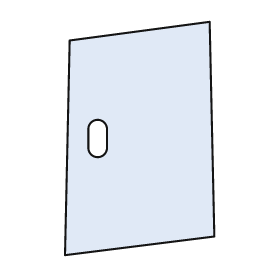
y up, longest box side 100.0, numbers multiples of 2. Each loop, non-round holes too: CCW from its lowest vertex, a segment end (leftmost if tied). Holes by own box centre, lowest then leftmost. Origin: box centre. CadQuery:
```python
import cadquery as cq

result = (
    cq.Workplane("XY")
    .moveTo(-32.0, -50.0)
    .lineTo(32.0, -42.0)
    .lineTo(30.0, 50.0)
    .lineTo(-30.0, 42.0)
    .close()
    .moveTo(-22.0, -4.0)
    .threePointArc((-18.0, -8.0), (-14.0, -4.0))
    .lineTo(-14.0, 4.0)
    .threePointArc((-18.0, 8.0), (-22.0, 4.0))
    .close()
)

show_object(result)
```